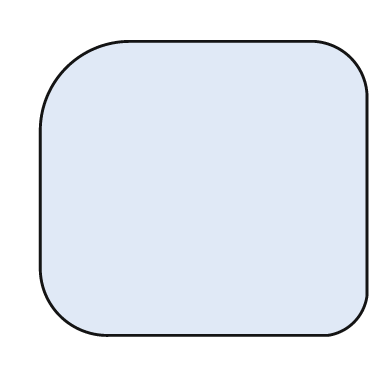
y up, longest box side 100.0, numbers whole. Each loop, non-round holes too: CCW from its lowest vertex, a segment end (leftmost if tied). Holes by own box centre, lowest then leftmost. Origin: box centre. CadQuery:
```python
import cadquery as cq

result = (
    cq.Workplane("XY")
    .moveTo(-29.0, -45.0)
    .lineTo(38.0, -45.0)
    .threePointArc((46.0, -41.0), (50.0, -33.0))
    .lineTo(50.0, 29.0)
    .threePointArc((45.0, 40.0), (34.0, 45.0))
    .lineTo(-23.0, 45.0)
    .threePointArc((-42.0, 37.0), (-50.0, 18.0))
    .lineTo(-50.0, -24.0)
    .threePointArc((-44.0, -39.0), (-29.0, -45.0))
    .close()
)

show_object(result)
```